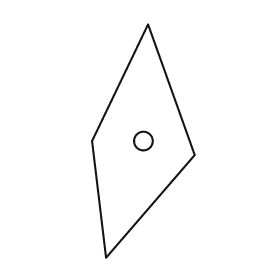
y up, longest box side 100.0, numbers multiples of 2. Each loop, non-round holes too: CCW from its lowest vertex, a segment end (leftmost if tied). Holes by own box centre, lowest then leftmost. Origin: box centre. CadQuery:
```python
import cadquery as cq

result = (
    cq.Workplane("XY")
    .moveTo(-16.0, -50.0)
    .lineTo(22.0, -6.0)
    .lineTo(2.0, 50.0)
    .lineTo(-22.0, 0.0)
    .close()
    .moveTo(0.0, 0.0)
    .circle(4.0)
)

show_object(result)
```